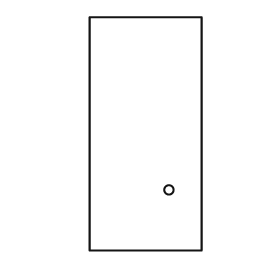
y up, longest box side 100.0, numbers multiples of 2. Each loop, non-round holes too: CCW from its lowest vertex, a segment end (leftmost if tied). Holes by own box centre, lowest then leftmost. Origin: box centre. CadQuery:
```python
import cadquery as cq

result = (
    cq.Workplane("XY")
    .moveTo(-24.0, -50.0)
    .lineTo(24.0, -50.0)
    .lineTo(24.0, 50.0)
    .lineTo(-24.0, 50.0)
    .close()
    .moveTo(10.0, -24.0)
    .circle(2.0)
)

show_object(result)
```